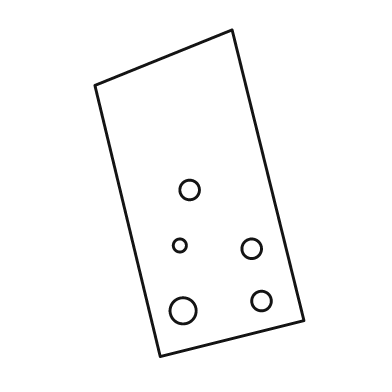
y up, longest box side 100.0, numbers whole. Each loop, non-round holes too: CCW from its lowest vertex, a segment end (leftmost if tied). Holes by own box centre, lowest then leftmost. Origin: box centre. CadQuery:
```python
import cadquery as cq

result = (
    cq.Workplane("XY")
    .moveTo(-12.0, -50.0)
    .lineTo(32.0, -39.0)
    .lineTo(10.0, 50.0)
    .lineTo(-32.0, 33.0)
    .close()
    .moveTo(-5.0, -36.0)
    .circle(4.0)
    .moveTo(19.0, -33.0)
    .circle(3.0)
    .moveTo(16.0, -17.0)
    .circle(3.0)
    .moveTo(-6.0, -16.0)
    .circle(2.0)
    .moveTo(-3.0, 1.0)
    .circle(3.0)
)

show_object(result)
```